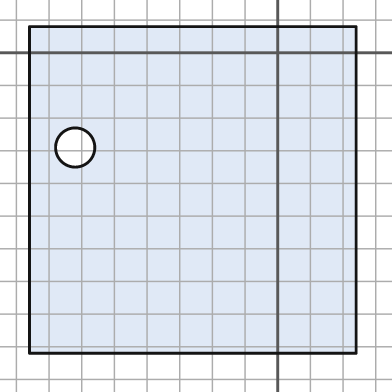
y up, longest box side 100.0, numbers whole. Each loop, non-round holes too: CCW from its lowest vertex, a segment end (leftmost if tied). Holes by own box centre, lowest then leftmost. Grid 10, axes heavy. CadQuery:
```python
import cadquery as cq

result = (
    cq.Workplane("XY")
    .moveTo(-76.0, -92.0)
    .lineTo(24.0, -92.0)
    .lineTo(24.0, 8.0)
    .lineTo(-76.0, 8.0)
    .close()
    .moveTo(-62.0, -29.0)
    .circle(6.0)
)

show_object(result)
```